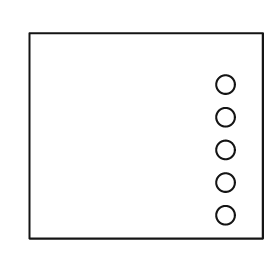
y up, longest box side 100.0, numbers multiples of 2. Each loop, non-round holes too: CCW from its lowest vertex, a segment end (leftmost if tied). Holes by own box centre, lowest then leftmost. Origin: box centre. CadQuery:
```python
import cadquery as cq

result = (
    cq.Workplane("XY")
    .moveTo(-50.0, -44.0)
    .lineTo(50.0, -44.0)
    .lineTo(50.0, 44.0)
    .lineTo(-50.0, 44.0)
    .close()
    .moveTo(34.0, -34.0)
    .circle(4.0)
    .moveTo(34.0, -20.0)
    .circle(4.0)
    .moveTo(34.0, -6.0)
    .circle(4.0)
    .moveTo(34.0, 8.0)
    .circle(4.0)
    .moveTo(34.0, 22.0)
    .circle(4.0)
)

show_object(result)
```